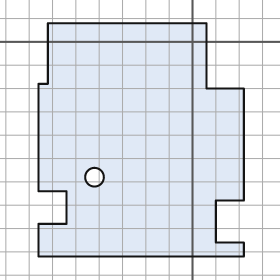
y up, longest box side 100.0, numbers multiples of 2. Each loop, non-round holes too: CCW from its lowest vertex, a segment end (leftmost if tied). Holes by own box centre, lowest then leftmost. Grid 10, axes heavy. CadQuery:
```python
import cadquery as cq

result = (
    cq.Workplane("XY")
    .moveTo(-66.0, -92.0)
    .lineTo(22.0, -92.0)
    .lineTo(22.0, -86.0)
    .lineTo(10.0, -86.0)
    .lineTo(10.0, -68.0)
    .lineTo(22.0, -68.0)
    .lineTo(22.0, -20.0)
    .lineTo(6.0, -20.0)
    .lineTo(6.0, 8.0)
    .lineTo(-62.0, 8.0)
    .lineTo(-62.0, -18.0)
    .lineTo(-66.0, -18.0)
    .lineTo(-66.0, -64.0)
    .lineTo(-54.0, -64.0)
    .lineTo(-54.0, -78.0)
    .lineTo(-66.0, -78.0)
    .close()
    .moveTo(-42.0, -58.0)
    .circle(4.0)
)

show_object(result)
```